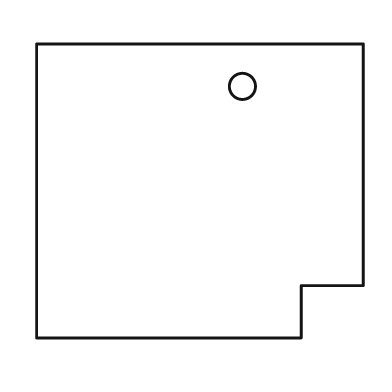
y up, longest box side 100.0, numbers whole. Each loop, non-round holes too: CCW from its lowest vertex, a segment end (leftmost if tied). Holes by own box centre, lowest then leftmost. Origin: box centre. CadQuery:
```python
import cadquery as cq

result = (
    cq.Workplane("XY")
    .moveTo(-50.0, -45.0)
    .lineTo(31.0, -45.0)
    .lineTo(31.0, -29.0)
    .lineTo(50.0, -29.0)
    .lineTo(50.0, 45.0)
    .lineTo(-50.0, 45.0)
    .close()
    .moveTo(13.0, 32.0)
    .circle(4.0)
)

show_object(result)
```